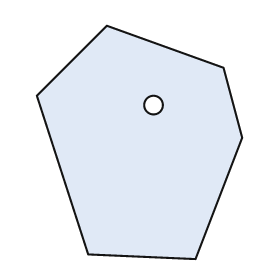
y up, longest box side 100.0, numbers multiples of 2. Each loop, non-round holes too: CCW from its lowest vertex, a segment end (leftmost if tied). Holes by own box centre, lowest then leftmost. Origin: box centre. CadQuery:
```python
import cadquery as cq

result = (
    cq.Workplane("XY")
    .moveTo(24.0, -50.0)
    .lineTo(44.0, 2.0)
    .lineTo(36.0, 32.0)
    .lineTo(-14.0, 50.0)
    .lineTo(-44.0, 20.0)
    .lineTo(-22.0, -48.0)
    .close()
    .moveTo(6.0, 16.0)
    .circle(4.0)
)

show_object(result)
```